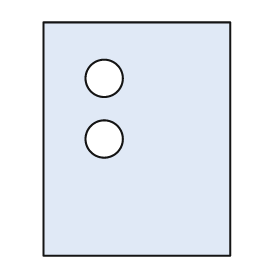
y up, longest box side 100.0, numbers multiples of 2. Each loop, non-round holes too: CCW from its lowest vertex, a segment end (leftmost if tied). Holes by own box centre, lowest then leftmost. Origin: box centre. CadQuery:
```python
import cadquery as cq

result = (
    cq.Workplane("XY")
    .moveTo(-40.0, -50.0)
    .lineTo(40.0, -50.0)
    .lineTo(40.0, 50.0)
    .lineTo(-40.0, 50.0)
    .close()
    .moveTo(-14.0, 0.0)
    .circle(8.0)
    .moveTo(-14.0, 26.0)
    .circle(8.0)
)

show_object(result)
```